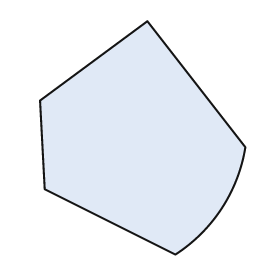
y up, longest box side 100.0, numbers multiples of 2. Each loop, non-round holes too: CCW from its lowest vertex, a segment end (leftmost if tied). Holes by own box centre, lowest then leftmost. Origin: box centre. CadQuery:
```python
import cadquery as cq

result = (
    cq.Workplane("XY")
    .moveTo(14.0, -50.0)
    .threePointArc((34.0, -30.0), (44.0, -4.0))
    .lineTo(2.0, 50.0)
    .lineTo(-44.0, 16.0)
    .lineTo(-42.0, -22.0)
    .close()
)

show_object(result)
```